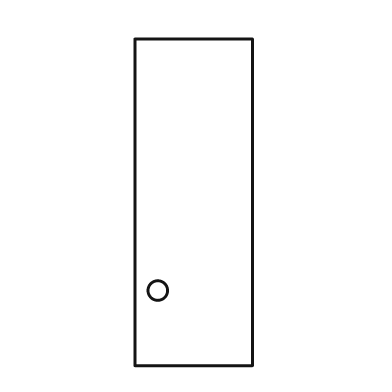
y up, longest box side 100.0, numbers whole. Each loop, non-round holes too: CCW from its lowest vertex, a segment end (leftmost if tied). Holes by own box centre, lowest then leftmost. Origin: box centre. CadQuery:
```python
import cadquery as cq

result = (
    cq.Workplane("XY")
    .moveTo(-18.0, -50.0)
    .lineTo(18.0, -50.0)
    .lineTo(18.0, 50.0)
    .lineTo(-18.0, 50.0)
    .close()
    .moveTo(-11.0, -27.0)
    .circle(3.0)
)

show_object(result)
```